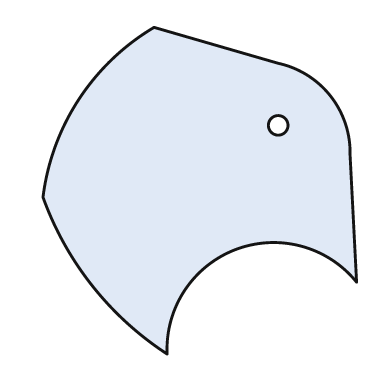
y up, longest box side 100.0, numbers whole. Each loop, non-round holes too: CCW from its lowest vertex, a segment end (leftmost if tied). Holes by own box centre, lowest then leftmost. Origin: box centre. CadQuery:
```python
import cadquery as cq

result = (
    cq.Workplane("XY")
    .moveTo(-10.0, -50.0)
    .threePointArc((11.0, -18.0), (48.0, -28.0))
    .lineTo(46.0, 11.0)
    .threePointArc((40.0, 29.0), (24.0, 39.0))
    .lineTo(-14.0, 50.0)
    .threePointArc((-37.0, 28.0), (-48.0, -2.0))
    .threePointArc((-33.0, -29.0), (-10.0, -50.0))
    .close()
    .moveTo(24.0, 20.0)
    .circle(3.0)
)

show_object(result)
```